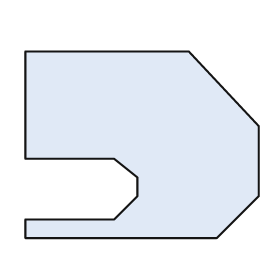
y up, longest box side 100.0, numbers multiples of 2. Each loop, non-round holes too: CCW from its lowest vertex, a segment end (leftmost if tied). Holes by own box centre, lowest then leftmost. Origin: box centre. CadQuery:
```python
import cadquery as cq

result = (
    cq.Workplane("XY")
    .moveTo(-50.0, -40.0)
    .lineTo(32.0, -40.0)
    .lineTo(50.0, -22.0)
    .lineTo(50.0, 8.0)
    .lineTo(20.0, 40.0)
    .lineTo(-50.0, 40.0)
    .lineTo(-50.0, -6.0)
    .lineTo(-12.0, -6.0)
    .lineTo(-2.0, -14.0)
    .lineTo(-2.0, -22.0)
    .lineTo(-12.0, -32.0)
    .lineTo(-50.0, -32.0)
    .close()
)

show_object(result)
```